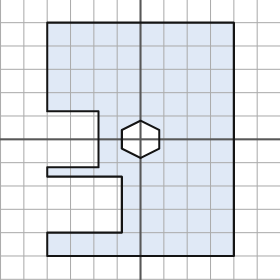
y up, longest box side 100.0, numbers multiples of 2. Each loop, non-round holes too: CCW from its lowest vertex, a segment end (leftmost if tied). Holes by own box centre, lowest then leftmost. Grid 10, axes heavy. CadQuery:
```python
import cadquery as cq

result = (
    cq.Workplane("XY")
    .moveTo(-40.0, -50.0)
    .lineTo(40.0, -50.0)
    .lineTo(40.0, 50.0)
    .lineTo(-40.0, 50.0)
    .lineTo(-40.0, 12.0)
    .lineTo(-18.0, 12.0)
    .lineTo(-18.0, -12.0)
    .lineTo(-40.0, -12.0)
    .lineTo(-40.0, -16.0)
    .lineTo(-8.0, -16.0)
    .lineTo(-8.0, -40.0)
    .lineTo(-40.0, -40.0)
    .close()
    .moveTo(0.0, -8.0)
    .lineTo(8.0, -4.0)
    .lineTo(8.0, 4.0)
    .lineTo(0.0, 8.0)
    .lineTo(-8.0, 4.0)
    .lineTo(-8.0, -4.0)
    .close()
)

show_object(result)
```